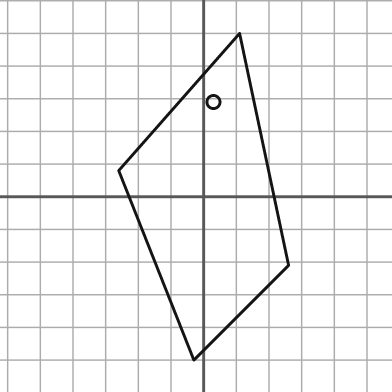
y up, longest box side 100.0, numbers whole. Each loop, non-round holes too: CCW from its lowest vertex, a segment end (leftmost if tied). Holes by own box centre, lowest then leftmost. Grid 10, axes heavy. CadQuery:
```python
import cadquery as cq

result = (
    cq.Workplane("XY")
    .moveTo(-3.0, -50.0)
    .lineTo(26.0, -21.0)
    .lineTo(11.0, 50.0)
    .lineTo(-26.0, 8.0)
    .close()
    .moveTo(3.0, 29.0)
    .circle(2.0)
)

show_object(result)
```